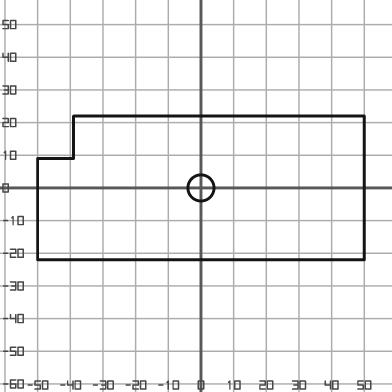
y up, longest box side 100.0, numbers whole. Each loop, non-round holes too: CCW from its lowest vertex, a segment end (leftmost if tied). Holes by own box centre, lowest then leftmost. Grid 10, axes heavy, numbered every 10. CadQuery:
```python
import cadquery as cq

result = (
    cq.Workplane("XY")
    .moveTo(-50.0, -22.0)
    .lineTo(50.0, -22.0)
    .lineTo(50.0, 22.0)
    .lineTo(-39.0, 22.0)
    .lineTo(-39.0, 9.0)
    .lineTo(-50.0, 9.0)
    .close()
    .moveTo(0.0, 0.0)
    .circle(4.0)
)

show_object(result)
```